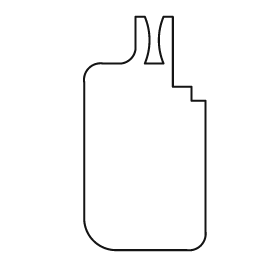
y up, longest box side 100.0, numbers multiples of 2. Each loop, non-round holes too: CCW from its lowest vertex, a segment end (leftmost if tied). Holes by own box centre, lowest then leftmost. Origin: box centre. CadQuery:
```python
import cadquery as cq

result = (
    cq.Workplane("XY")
    .moveTo(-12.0, -50.0)
    .lineTo(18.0, -50.0)
    .threePointArc((24.0, -48.0), (26.0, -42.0))
    .lineTo(26.0, 14.0)
    .lineTo(20.0, 14.0)
    .lineTo(20.0, 20.0)
    .lineTo(12.0, 20.0)
    .lineTo(12.0, 50.0)
    .lineTo(8.0, 50.0)
    .threePointArc((6.0, 40.0), (8.0, 30.0))
    .lineTo(0.0, 30.0)
    .threePointArc((2.0, 40.0), (0.0, 50.0))
    .lineTo(-4.0, 50.0)
    .lineTo(-4.0, 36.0)
    .threePointArc((-6.0, 32.0), (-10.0, 30.0))
    .lineTo(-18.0, 30.0)
    .threePointArc((-24.0, 28.0), (-26.0, 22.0))
    .lineTo(-26.0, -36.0)
    .threePointArc((-22.0, -46.0), (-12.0, -50.0))
    .close()
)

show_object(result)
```